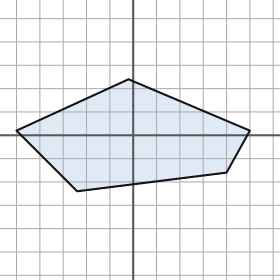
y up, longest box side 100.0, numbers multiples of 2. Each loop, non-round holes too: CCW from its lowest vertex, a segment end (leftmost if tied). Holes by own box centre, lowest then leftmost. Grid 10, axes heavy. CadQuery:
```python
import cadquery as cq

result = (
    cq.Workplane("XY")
    .moveTo(-24.0, -24.0)
    .lineTo(40.0, -16.0)
    .lineTo(50.0, 2.0)
    .lineTo(-2.0, 24.0)
    .lineTo(-50.0, 2.0)
    .close()
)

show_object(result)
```